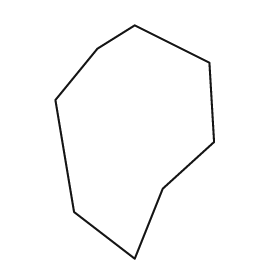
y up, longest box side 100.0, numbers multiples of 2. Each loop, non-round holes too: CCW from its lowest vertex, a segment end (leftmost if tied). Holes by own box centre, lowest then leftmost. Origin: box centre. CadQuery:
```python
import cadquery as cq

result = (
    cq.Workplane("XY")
    .moveTo(0.0, -50.0)
    .lineTo(12.0, -20.0)
    .lineTo(34.0, 0.0)
    .lineTo(32.0, 34.0)
    .lineTo(0.0, 50.0)
    .lineTo(-16.0, 40.0)
    .lineTo(-34.0, 18.0)
    .lineTo(-26.0, -30.0)
    .close()
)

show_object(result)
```